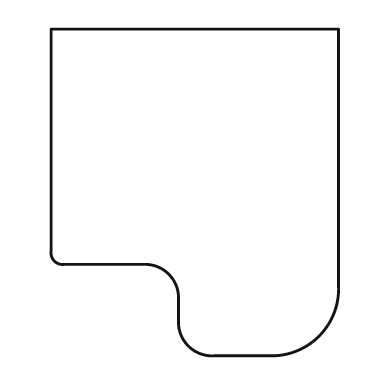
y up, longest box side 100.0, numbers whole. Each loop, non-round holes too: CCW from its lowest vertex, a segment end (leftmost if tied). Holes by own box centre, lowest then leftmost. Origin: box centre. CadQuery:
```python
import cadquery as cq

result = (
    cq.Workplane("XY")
    .moveTo(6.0, -50.0)
    .lineTo(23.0, -50.0)
    .threePointArc((38.0, -44.0), (44.0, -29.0))
    .lineTo(44.0, 50.0)
    .lineTo(-44.0, 50.0)
    .lineTo(-44.0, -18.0)
    .threePointArc((-43.0, -21.0), (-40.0, -22.0))
    .lineTo(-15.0, -22.0)
    .threePointArc((-8.0, -25.0), (-5.0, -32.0))
    .lineTo(-5.0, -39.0)
    .threePointArc((-2.0, -47.0), (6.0, -50.0))
    .close()
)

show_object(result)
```